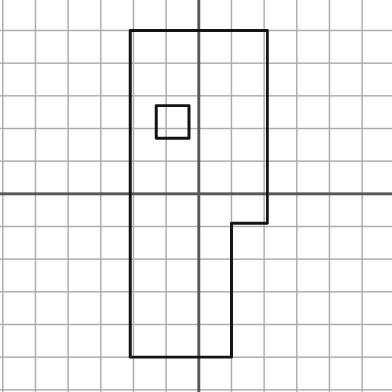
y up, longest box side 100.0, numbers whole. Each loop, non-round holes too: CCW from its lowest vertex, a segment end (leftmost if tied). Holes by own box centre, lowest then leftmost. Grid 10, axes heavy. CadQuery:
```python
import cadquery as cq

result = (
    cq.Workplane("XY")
    .moveTo(-21.0, -50.0)
    .lineTo(10.0, -50.0)
    .lineTo(10.0, -9.0)
    .lineTo(21.0, -9.0)
    .lineTo(21.0, 50.0)
    .lineTo(-21.0, 50.0)
    .close()
    .moveTo(-13.0, 17.0)
    .lineTo(-3.0, 17.0)
    .lineTo(-3.0, 27.0)
    .lineTo(-13.0, 27.0)
    .close()
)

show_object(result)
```